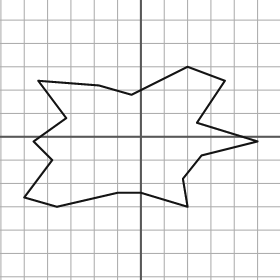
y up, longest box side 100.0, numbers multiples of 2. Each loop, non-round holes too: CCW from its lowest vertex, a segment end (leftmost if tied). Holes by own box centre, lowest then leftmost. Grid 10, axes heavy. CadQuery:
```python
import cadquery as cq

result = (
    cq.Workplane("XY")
    .moveTo(-36.0, -30.0)
    .lineTo(-10.0, -24.0)
    .lineTo(0.0, -24.0)
    .lineTo(20.0, -30.0)
    .lineTo(18.0, -18.0)
    .lineTo(26.0, -8.0)
    .lineTo(50.0, -2.0)
    .lineTo(24.0, 6.0)
    .lineTo(36.0, 24.0)
    .lineTo(20.0, 30.0)
    .lineTo(-4.0, 18.0)
    .lineTo(-18.0, 22.0)
    .lineTo(-44.0, 24.0)
    .lineTo(-32.0, 8.0)
    .lineTo(-46.0, -2.0)
    .lineTo(-38.0, -10.0)
    .lineTo(-50.0, -26.0)
    .close()
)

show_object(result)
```